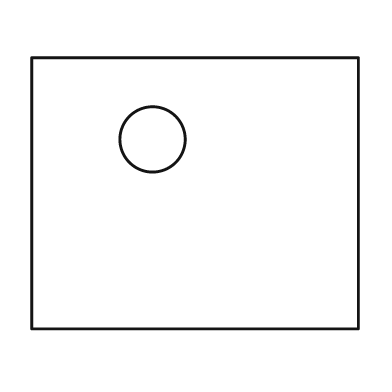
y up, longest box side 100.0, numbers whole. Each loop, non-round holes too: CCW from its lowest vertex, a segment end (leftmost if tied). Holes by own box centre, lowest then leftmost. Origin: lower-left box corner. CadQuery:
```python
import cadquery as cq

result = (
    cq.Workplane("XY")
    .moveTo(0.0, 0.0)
    .lineTo(100.0, 0.0)
    .lineTo(100.0, 83.0)
    .lineTo(0.0, 83.0)
    .close()
    .moveTo(37.0, 58.0)
    .circle(10.0)
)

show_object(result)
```